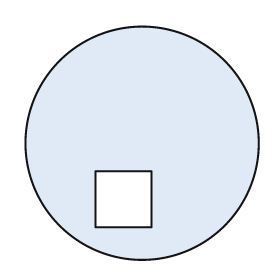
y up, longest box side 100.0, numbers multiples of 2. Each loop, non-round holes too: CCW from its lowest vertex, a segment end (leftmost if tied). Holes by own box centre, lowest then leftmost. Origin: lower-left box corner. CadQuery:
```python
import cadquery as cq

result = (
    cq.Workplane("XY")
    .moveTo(50.0, 50.0)
    .circle(50.0)
    .moveTo(30.0, 14.0)
    .lineTo(54.0, 14.0)
    .lineTo(54.0, 38.0)
    .lineTo(30.0, 38.0)
    .close()
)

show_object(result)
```